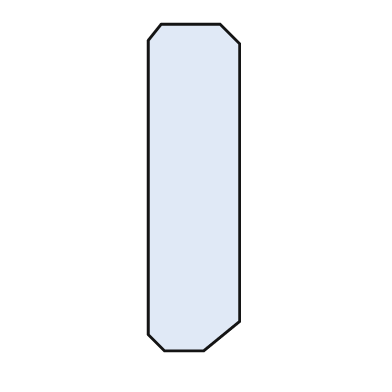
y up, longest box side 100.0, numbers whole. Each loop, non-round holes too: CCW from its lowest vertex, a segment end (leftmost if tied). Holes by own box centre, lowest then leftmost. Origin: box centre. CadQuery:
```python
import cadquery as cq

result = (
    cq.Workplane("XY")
    .moveTo(-9.0, -50.0)
    .lineTo(3.0, -50.0)
    .lineTo(14.0, -41.0)
    .lineTo(14.0, 44.0)
    .lineTo(8.0, 50.0)
    .lineTo(-10.0, 50.0)
    .lineTo(-14.0, 45.0)
    .lineTo(-14.0, -45.0)
    .close()
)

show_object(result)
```